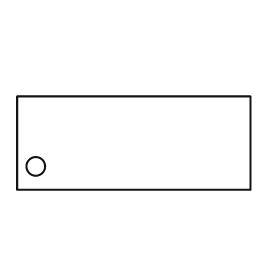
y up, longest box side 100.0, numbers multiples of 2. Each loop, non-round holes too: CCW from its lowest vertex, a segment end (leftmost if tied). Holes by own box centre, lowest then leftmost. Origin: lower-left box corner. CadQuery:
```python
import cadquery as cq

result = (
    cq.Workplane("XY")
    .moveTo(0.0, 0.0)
    .lineTo(100.0, 0.0)
    .lineTo(100.0, 40.0)
    .lineTo(0.0, 40.0)
    .close()
    .moveTo(8.0, 10.0)
    .circle(4.0)
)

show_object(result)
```